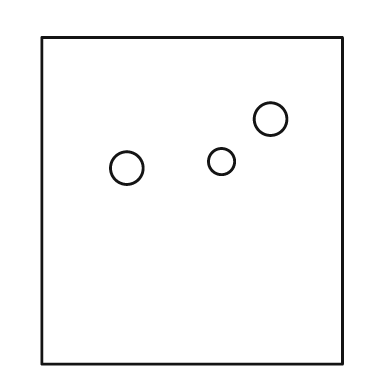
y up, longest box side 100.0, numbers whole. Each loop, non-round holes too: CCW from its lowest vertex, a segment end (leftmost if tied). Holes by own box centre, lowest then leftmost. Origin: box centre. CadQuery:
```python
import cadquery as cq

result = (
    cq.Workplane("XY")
    .moveTo(-46.0, -50.0)
    .lineTo(46.0, -50.0)
    .lineTo(46.0, 50.0)
    .lineTo(-46.0, 50.0)
    .close()
    .moveTo(-20.0, 10.0)
    .circle(5.0)
    .moveTo(9.0, 12.0)
    .circle(4.0)
    .moveTo(24.0, 25.0)
    .circle(5.0)
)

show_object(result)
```